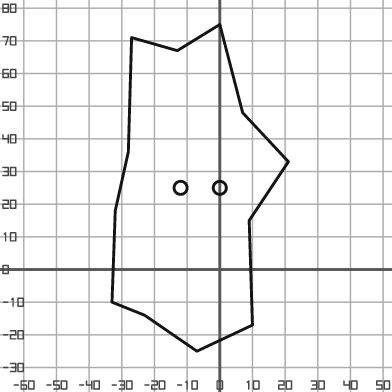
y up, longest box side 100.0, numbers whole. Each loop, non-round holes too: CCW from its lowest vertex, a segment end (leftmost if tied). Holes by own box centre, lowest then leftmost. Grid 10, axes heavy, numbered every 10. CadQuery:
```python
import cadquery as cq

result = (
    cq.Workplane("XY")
    .moveTo(-7.0, -25.0)
    .lineTo(10.0, -17.0)
    .lineTo(9.0, 15.0)
    .lineTo(21.0, 33.0)
    .lineTo(7.0, 48.0)
    .lineTo(0.0, 75.0)
    .lineTo(-13.0, 67.0)
    .lineTo(-27.0, 71.0)
    .lineTo(-28.0, 36.0)
    .lineTo(-32.0, 18.0)
    .lineTo(-33.0, -10.0)
    .lineTo(-23.0, -14.0)
    .close()
    .moveTo(-12.0, 25.0)
    .circle(2.0)
    .moveTo(0.0, 25.0)
    .circle(2.0)
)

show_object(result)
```